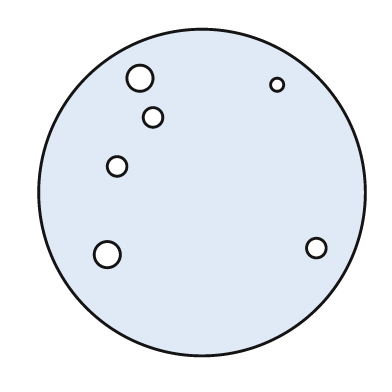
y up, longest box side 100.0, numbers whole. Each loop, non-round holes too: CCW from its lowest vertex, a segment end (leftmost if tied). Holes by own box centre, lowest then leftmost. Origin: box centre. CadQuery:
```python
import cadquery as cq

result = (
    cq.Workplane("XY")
    .moveTo(0.0, 0.0)
    .circle(50.0)
    .moveTo(-29.0, -19.0)
    .circle(4.0)
    .moveTo(35.0, -17.0)
    .circle(3.0)
    .moveTo(-26.0, 8.0)
    .circle(3.0)
    .moveTo(-15.0, 23.0)
    .circle(3.0)
    .moveTo(23.0, 33.0)
    .circle(2.0)
    .moveTo(-19.0, 35.0)
    .circle(4.0)
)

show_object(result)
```